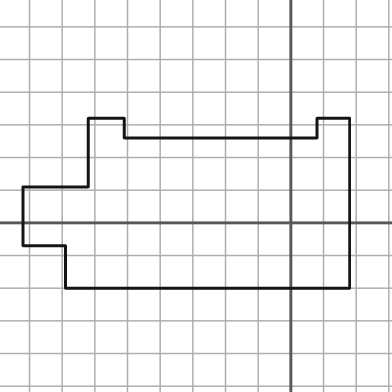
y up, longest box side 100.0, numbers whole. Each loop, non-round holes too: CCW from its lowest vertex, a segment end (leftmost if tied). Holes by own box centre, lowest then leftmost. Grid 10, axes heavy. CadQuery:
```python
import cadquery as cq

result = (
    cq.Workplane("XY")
    .moveTo(-69.0, -20.0)
    .lineTo(18.0, -20.0)
    .lineTo(18.0, 32.0)
    .lineTo(8.0, 32.0)
    .lineTo(8.0, 26.0)
    .lineTo(-51.0, 26.0)
    .lineTo(-51.0, 32.0)
    .lineTo(-62.0, 32.0)
    .lineTo(-62.0, 11.0)
    .lineTo(-82.0, 11.0)
    .lineTo(-82.0, -7.0)
    .lineTo(-69.0, -7.0)
    .close()
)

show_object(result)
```